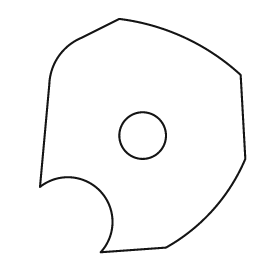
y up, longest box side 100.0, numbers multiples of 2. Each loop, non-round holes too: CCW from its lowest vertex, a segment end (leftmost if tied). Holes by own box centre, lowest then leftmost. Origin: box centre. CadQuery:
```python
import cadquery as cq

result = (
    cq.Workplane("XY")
    .moveTo(-18.0, -50.0)
    .lineTo(10.0, -48.0)
    .threePointArc((30.0, -32.0), (44.0, -10.0))
    .lineTo(42.0, 26.0)
    .threePointArc((18.0, 42.0), (-10.0, 50.0))
    .lineTo(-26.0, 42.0)
    .threePointArc((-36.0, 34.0), (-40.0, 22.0))
    .lineTo(-44.0, -22.0)
    .threePointArc((-18.0, -24.0), (-18.0, -50.0))
    .close()
    .moveTo(0.0, 0.0)
    .circle(10.0)
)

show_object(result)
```